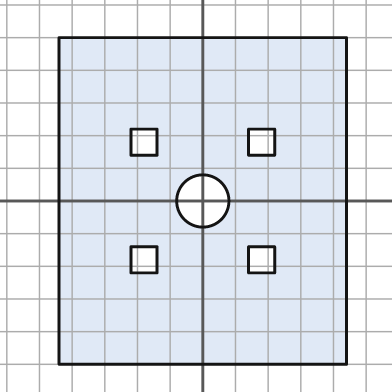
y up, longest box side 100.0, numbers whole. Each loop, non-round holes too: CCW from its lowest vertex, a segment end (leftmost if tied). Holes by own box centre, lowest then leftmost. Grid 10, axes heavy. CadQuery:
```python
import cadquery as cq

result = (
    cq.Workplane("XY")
    .moveTo(-44.0, -50.0)
    .lineTo(44.0, -50.0)
    .lineTo(44.0, 50.0)
    .lineTo(-44.0, 50.0)
    .close()
    .moveTo(-22.0, -22.0)
    .lineTo(-14.0, -22.0)
    .lineTo(-14.0, -14.0)
    .lineTo(-22.0, -14.0)
    .close()
    .moveTo(14.0, -22.0)
    .lineTo(22.0, -22.0)
    .lineTo(22.0, -14.0)
    .lineTo(14.0, -14.0)
    .close()
    .moveTo(0.0, 0.0)
    .circle(8.0)
    .moveTo(-22.0, 14.0)
    .lineTo(-14.0, 14.0)
    .lineTo(-14.0, 22.0)
    .lineTo(-22.0, 22.0)
    .close()
    .moveTo(14.0, 14.0)
    .lineTo(22.0, 14.0)
    .lineTo(22.0, 22.0)
    .lineTo(14.0, 22.0)
    .close()
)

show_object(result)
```